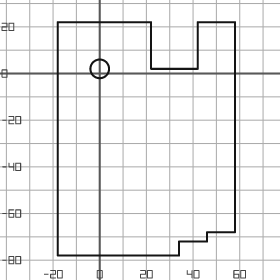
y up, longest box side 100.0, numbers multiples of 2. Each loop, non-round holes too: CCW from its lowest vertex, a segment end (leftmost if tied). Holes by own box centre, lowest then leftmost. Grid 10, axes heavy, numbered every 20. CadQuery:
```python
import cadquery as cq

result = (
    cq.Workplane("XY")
    .moveTo(-18.0, -78.0)
    .lineTo(34.0, -78.0)
    .lineTo(34.0, -72.0)
    .lineTo(46.0, -72.0)
    .lineTo(46.0, -68.0)
    .lineTo(58.0, -68.0)
    .lineTo(58.0, 22.0)
    .lineTo(42.0, 22.0)
    .lineTo(42.0, 2.0)
    .lineTo(22.0, 2.0)
    .lineTo(22.0, 22.0)
    .lineTo(-18.0, 22.0)
    .close()
    .moveTo(0.0, 2.0)
    .circle(4.0)
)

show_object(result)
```